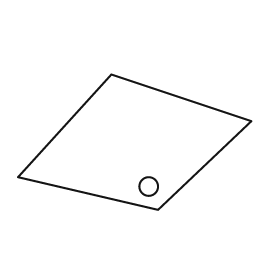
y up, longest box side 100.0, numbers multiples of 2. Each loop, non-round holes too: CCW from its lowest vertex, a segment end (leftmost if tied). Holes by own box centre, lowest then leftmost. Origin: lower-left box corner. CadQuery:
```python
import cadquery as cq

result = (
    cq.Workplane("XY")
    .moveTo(60.0, 0.0)
    .lineTo(100.0, 38.0)
    .lineTo(40.0, 58.0)
    .lineTo(0.0, 14.0)
    .close()
    .moveTo(56.0, 10.0)
    .circle(4.0)
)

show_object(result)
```